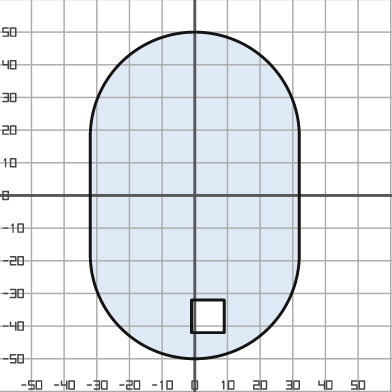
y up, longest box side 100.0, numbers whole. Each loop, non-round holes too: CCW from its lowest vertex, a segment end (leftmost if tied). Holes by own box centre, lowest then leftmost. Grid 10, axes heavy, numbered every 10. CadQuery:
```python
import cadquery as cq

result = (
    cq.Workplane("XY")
    .moveTo(-32.0, -18.0)
    .threePointArc((0.0, -50.0), (32.0, -18.0))
    .lineTo(32.0, 18.0)
    .threePointArc((0.0, 50.0), (-32.0, 18.0))
    .close()
    .moveTo(-1.0, -42.0)
    .lineTo(9.0, -42.0)
    .lineTo(9.0, -32.0)
    .lineTo(-1.0, -32.0)
    .close()
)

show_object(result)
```